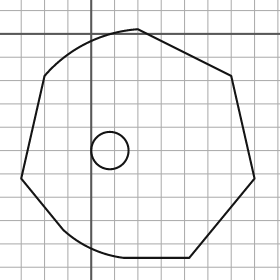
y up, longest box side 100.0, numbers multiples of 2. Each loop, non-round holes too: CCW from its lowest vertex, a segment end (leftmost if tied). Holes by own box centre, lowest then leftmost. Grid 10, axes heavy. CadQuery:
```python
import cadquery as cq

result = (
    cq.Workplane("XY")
    .moveTo(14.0, -96.0)
    .lineTo(42.0, -96.0)
    .lineTo(70.0, -62.0)
    .lineTo(60.0, -18.0)
    .lineTo(20.0, 2.0)
    .threePointArc((-2.0, -4.0), (-20.0, -18.0))
    .lineTo(-30.0, -62.0)
    .lineTo(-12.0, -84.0)
    .threePointArc((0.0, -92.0), (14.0, -96.0))
    .close()
    .moveTo(8.0, -50.0)
    .circle(8.0)
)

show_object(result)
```